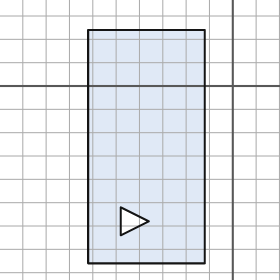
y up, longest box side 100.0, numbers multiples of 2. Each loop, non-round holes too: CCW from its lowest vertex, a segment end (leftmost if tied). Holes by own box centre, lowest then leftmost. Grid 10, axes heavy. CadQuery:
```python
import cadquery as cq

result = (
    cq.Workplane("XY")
    .moveTo(-62.0, -76.0)
    .lineTo(-12.0, -76.0)
    .lineTo(-12.0, 24.0)
    .lineTo(-62.0, 24.0)
    .close()
    .moveTo(-48.0, -64.0)
    .lineTo(-36.0, -58.0)
    .lineTo(-48.0, -52.0)
    .close()
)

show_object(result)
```